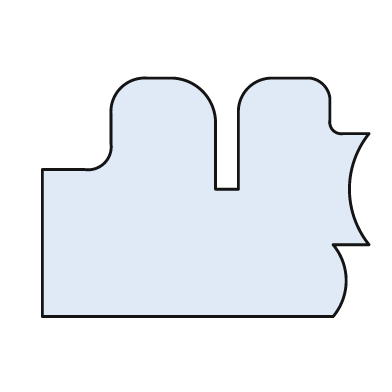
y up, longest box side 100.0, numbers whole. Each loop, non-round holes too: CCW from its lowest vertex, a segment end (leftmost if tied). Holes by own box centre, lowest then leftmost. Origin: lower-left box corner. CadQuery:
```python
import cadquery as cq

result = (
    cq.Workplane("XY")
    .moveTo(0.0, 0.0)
    .lineTo(89.0, 0.0)
    .threePointArc((93.0, 11.0), (89.0, 22.0))
    .lineTo(100.0, 22.0)
    .threePointArc((94.0, 39.0), (100.0, 56.0))
    .lineTo(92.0, 56.0)
    .threePointArc((89.0, 57.0), (88.0, 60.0))
    .lineTo(88.0, 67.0)
    .threePointArc((86.0, 71.0), (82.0, 73.0))
    .lineTo(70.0, 73.0)
    .threePointArc((63.0, 70.0), (60.0, 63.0))
    .lineTo(60.0, 39.0)
    .lineTo(53.0, 39.0)
    .lineTo(53.0, 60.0)
    .threePointArc((49.0, 69.0), (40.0, 73.0))
    .lineTo(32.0, 73.0)
    .threePointArc((24.0, 70.0), (21.0, 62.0))
    .lineTo(21.0, 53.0)
    .threePointArc((19.0, 47.0), (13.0, 45.0))
    .lineTo(0.0, 45.0)
    .close()
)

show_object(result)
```